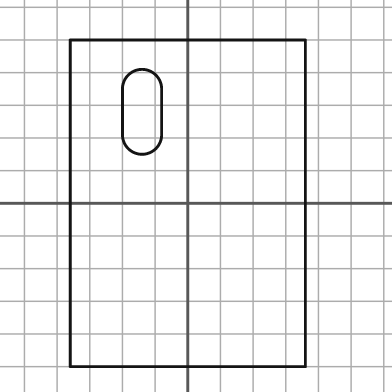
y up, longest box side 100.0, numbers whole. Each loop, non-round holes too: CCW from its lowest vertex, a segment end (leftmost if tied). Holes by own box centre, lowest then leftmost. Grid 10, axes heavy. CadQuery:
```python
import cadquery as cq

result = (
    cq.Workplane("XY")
    .moveTo(-36.0, -50.0)
    .lineTo(36.0, -50.0)
    .lineTo(36.0, 50.0)
    .lineTo(-36.0, 50.0)
    .close()
    .moveTo(-20.0, 21.0)
    .threePointArc((-14.0, 15.0), (-8.0, 21.0))
    .lineTo(-8.0, 35.0)
    .threePointArc((-14.0, 41.0), (-20.0, 35.0))
    .close()
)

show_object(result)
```